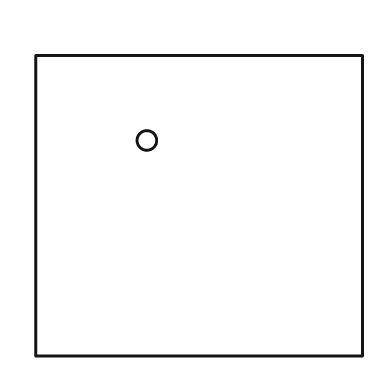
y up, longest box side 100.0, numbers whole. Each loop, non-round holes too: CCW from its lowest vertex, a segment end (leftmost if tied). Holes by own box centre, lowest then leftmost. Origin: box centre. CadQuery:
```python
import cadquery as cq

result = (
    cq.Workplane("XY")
    .moveTo(-50.0, -46.0)
    .lineTo(50.0, -46.0)
    .lineTo(50.0, 46.0)
    .lineTo(-50.0, 46.0)
    .close()
    .moveTo(-16.0, 20.0)
    .circle(3.0)
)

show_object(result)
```